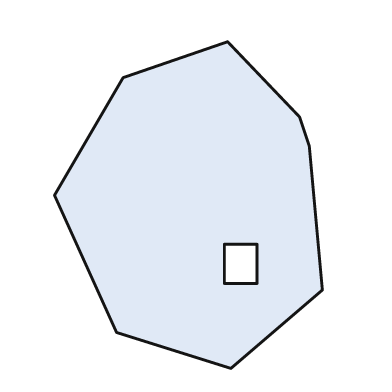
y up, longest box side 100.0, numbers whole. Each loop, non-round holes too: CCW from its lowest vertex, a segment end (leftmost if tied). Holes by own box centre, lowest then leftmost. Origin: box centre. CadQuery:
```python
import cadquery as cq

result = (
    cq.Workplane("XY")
    .moveTo(13.0, -50.0)
    .lineTo(41.0, -26.0)
    .lineTo(37.0, 18.0)
    .lineTo(34.0, 27.0)
    .lineTo(12.0, 50.0)
    .lineTo(-20.0, 39.0)
    .lineTo(-41.0, 3.0)
    .lineTo(-22.0, -39.0)
    .close()
    .moveTo(11.0, -24.0)
    .lineTo(21.0, -24.0)
    .lineTo(21.0, -12.0)
    .lineTo(11.0, -12.0)
    .close()
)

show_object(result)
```